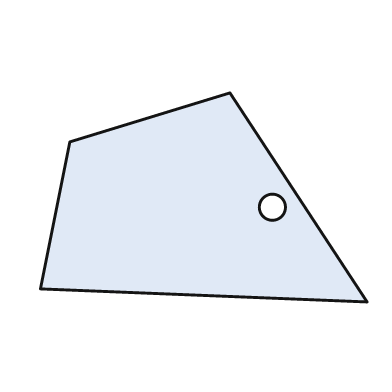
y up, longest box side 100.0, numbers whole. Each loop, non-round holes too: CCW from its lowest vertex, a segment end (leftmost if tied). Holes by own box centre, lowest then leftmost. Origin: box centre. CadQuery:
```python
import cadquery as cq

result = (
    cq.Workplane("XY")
    .moveTo(50.0, -32.0)
    .lineTo(8.0, 32.0)
    .lineTo(-41.0, 17.0)
    .lineTo(-50.0, -28.0)
    .close()
    .moveTo(21.0, -3.0)
    .circle(4.0)
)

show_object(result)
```